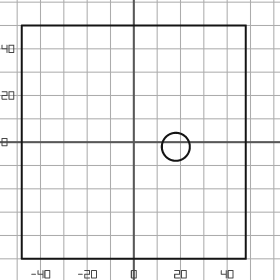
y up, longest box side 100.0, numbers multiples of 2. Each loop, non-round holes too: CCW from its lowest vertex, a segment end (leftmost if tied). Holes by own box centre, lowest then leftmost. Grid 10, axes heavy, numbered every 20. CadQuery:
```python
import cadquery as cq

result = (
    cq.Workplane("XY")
    .moveTo(-48.0, -50.0)
    .lineTo(48.0, -50.0)
    .lineTo(48.0, 50.0)
    .lineTo(-48.0, 50.0)
    .close()
    .moveTo(18.0, -2.0)
    .circle(6.0)
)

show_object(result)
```